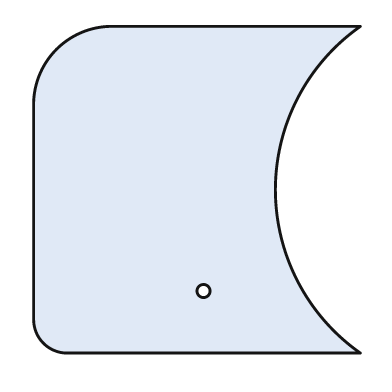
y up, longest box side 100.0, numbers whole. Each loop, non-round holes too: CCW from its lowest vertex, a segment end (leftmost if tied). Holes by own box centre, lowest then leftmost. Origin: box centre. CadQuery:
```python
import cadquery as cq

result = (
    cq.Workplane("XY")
    .moveTo(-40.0, -50.0)
    .lineTo(50.0, -50.0)
    .threePointArc((24.0, 0.0), (50.0, 50.0))
    .lineTo(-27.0, 50.0)
    .threePointArc((-43.0, 43.0), (-50.0, 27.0))
    .lineTo(-50.0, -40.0)
    .threePointArc((-47.0, -47.0), (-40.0, -50.0))
    .close()
    .moveTo(2.0, -31.0)
    .circle(2.0)
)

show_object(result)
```